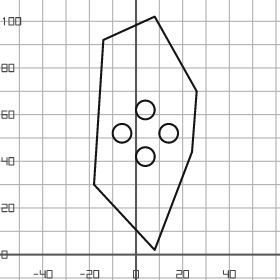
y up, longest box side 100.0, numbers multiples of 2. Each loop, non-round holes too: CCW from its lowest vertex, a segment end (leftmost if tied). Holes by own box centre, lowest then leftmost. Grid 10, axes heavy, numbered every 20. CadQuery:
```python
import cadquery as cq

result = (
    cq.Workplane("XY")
    .moveTo(8.0, 2.0)
    .lineTo(24.0, 44.0)
    .lineTo(26.0, 70.0)
    .lineTo(8.0, 102.0)
    .lineTo(-14.0, 92.0)
    .lineTo(-18.0, 30.0)
    .close()
    .moveTo(4.0, 42.0)
    .circle(4.0)
    .moveTo(-6.0, 52.0)
    .circle(4.0)
    .moveTo(14.0, 52.0)
    .circle(4.0)
    .moveTo(4.0, 62.0)
    .circle(4.0)
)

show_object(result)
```